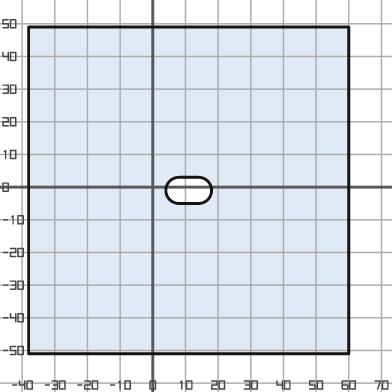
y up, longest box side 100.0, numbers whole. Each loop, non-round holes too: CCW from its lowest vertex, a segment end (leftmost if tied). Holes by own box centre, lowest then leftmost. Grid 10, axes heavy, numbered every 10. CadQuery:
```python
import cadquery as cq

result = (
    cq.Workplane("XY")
    .moveTo(-38.0, -51.0)
    .lineTo(60.0, -51.0)
    .lineTo(60.0, 49.0)
    .lineTo(-38.0, 49.0)
    .close()
    .moveTo(8.0, -5.0)
    .lineTo(14.0, -5.0)
    .threePointArc((18.0, -1.0), (14.0, 3.0))
    .lineTo(8.0, 3.0)
    .threePointArc((4.0, -1.0), (8.0, -5.0))
    .close()
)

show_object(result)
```